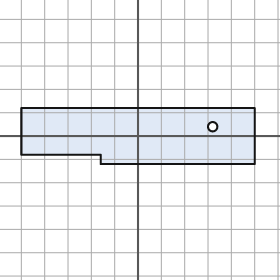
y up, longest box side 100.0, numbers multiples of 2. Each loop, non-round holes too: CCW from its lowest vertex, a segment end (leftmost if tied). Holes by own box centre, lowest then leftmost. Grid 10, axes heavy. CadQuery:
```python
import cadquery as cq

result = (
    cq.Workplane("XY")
    .moveTo(-16.0, -12.0)
    .lineTo(50.0, -12.0)
    .lineTo(50.0, 12.0)
    .lineTo(-50.0, 12.0)
    .lineTo(-50.0, -8.0)
    .lineTo(-16.0, -8.0)
    .close()
    .moveTo(32.0, 4.0)
    .circle(2.0)
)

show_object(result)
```